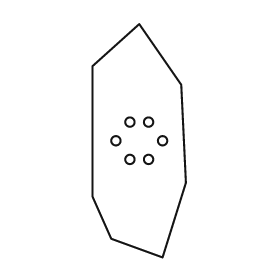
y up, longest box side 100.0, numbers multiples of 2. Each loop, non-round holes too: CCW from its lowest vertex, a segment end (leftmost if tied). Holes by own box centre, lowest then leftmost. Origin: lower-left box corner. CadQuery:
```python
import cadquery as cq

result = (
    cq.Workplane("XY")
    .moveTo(30.0, 0.0)
    .lineTo(40.0, 32.0)
    .lineTo(38.0, 74.0)
    .lineTo(20.0, 100.0)
    .lineTo(0.0, 82.0)
    .lineTo(0.0, 26.0)
    .lineTo(8.0, 8.0)
    .close()
    .moveTo(16.0, 42.0)
    .circle(2.0)
    .moveTo(24.0, 42.0)
    .circle(2.0)
    .moveTo(10.0, 50.0)
    .circle(2.0)
    .moveTo(30.0, 50.0)
    .circle(2.0)
    .moveTo(16.0, 58.0)
    .circle(2.0)
    .moveTo(24.0, 58.0)
    .circle(2.0)
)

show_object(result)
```